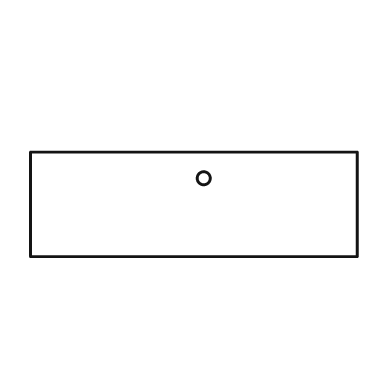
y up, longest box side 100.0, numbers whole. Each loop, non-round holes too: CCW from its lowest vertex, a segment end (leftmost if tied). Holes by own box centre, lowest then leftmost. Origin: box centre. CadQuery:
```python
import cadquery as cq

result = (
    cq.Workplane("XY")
    .moveTo(-50.0, -16.0)
    .lineTo(50.0, -16.0)
    .lineTo(50.0, 16.0)
    .lineTo(-50.0, 16.0)
    .close()
    .moveTo(3.0, 8.0)
    .circle(2.0)
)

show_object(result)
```